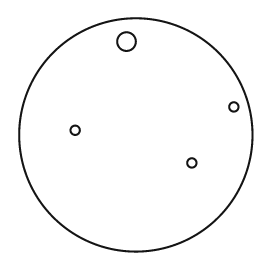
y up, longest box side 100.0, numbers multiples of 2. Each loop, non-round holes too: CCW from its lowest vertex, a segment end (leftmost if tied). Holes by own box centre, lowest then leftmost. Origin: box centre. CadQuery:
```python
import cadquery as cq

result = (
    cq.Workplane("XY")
    .moveTo(0.0, 0.0)
    .circle(50.0)
    .moveTo(24.0, -12.0)
    .circle(2.0)
    .moveTo(-26.0, 2.0)
    .circle(2.0)
    .moveTo(42.0, 12.0)
    .circle(2.0)
    .moveTo(-4.0, 40.0)
    .circle(4.0)
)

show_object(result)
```